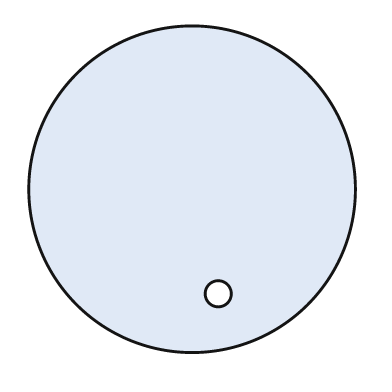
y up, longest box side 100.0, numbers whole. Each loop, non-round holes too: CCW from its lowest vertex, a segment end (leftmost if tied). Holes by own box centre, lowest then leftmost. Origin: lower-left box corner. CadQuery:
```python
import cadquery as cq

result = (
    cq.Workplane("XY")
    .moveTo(50.0, 50.0)
    .circle(50.0)
    .moveTo(58.0, 18.0)
    .circle(4.0)
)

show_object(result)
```